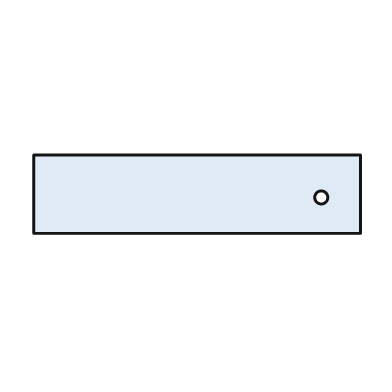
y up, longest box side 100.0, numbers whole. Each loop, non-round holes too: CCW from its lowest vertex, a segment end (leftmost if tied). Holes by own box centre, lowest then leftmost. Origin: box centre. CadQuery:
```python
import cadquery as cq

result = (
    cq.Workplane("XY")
    .moveTo(-50.0, -12.0)
    .lineTo(50.0, -12.0)
    .lineTo(50.0, 12.0)
    .lineTo(-50.0, 12.0)
    .close()
    .moveTo(38.0, -1.0)
    .circle(2.0)
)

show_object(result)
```